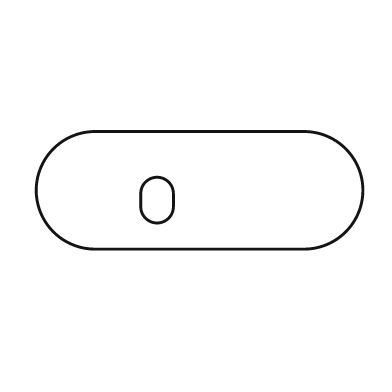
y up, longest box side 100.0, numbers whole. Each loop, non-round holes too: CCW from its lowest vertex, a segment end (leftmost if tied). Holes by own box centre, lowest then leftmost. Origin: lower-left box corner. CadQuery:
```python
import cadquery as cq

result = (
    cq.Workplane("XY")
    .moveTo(18.0, 0.0)
    .lineTo(82.0, 0.0)
    .threePointArc((100.0, 18.0), (82.0, 36.0))
    .lineTo(18.0, 36.0)
    .threePointArc((0.0, 18.0), (18.0, 0.0))
    .close()
    .moveTo(32.0, 13.0)
    .threePointArc((37.0, 8.0), (42.0, 13.0))
    .lineTo(42.0, 17.0)
    .threePointArc((37.0, 22.0), (32.0, 17.0))
    .close()
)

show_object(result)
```